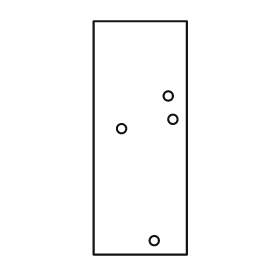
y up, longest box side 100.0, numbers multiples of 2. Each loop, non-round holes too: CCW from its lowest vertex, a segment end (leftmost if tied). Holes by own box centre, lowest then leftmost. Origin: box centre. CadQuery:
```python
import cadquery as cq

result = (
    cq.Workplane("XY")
    .moveTo(-20.0, -50.0)
    .lineTo(20.0, -50.0)
    .lineTo(20.0, 50.0)
    .lineTo(-20.0, 50.0)
    .close()
    .moveTo(6.0, -44.0)
    .circle(2.0)
    .moveTo(-8.0, 4.0)
    .circle(2.0)
    .moveTo(14.0, 8.0)
    .circle(2.0)
    .moveTo(12.0, 18.0)
    .circle(2.0)
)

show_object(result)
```